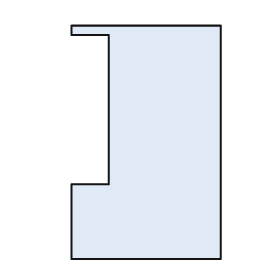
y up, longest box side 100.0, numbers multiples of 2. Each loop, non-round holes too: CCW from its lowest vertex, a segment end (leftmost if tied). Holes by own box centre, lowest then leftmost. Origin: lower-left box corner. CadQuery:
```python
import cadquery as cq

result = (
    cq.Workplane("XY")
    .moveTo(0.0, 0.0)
    .lineTo(64.0, 0.0)
    .lineTo(64.0, 100.0)
    .lineTo(0.0, 100.0)
    .lineTo(0.0, 96.0)
    .lineTo(16.0, 96.0)
    .lineTo(16.0, 32.0)
    .lineTo(0.0, 32.0)
    .close()
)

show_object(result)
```